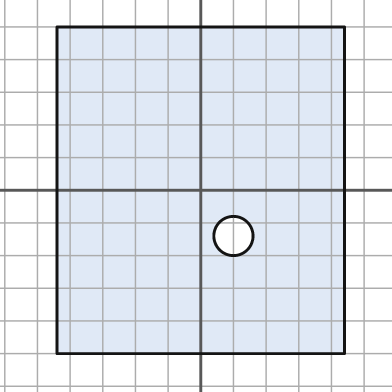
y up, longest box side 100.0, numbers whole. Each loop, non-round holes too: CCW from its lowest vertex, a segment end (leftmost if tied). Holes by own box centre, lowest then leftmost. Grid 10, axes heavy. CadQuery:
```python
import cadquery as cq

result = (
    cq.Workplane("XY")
    .moveTo(-44.0, -50.0)
    .lineTo(44.0, -50.0)
    .lineTo(44.0, 50.0)
    .lineTo(-44.0, 50.0)
    .close()
    .moveTo(10.0, -14.0)
    .circle(6.0)
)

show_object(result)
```